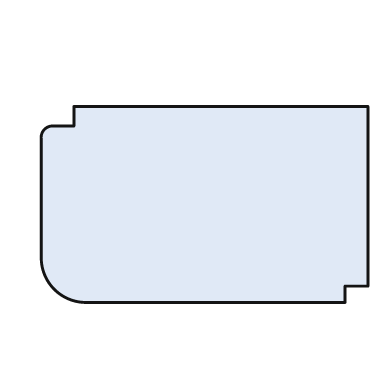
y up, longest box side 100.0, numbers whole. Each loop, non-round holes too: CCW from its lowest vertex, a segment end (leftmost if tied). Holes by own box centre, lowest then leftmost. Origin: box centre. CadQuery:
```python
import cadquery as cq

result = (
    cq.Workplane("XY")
    .moveTo(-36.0, -30.0)
    .lineTo(43.0, -30.0)
    .lineTo(43.0, -25.0)
    .lineTo(50.0, -25.0)
    .lineTo(50.0, 30.0)
    .lineTo(-40.0, 30.0)
    .lineTo(-40.0, 24.0)
    .lineTo(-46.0, 24.0)
    .threePointArc((-49.0, 23.0), (-50.0, 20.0))
    .lineTo(-50.0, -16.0)
    .threePointArc((-46.0, -26.0), (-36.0, -30.0))
    .close()
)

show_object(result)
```